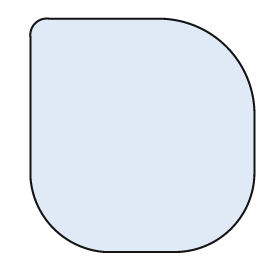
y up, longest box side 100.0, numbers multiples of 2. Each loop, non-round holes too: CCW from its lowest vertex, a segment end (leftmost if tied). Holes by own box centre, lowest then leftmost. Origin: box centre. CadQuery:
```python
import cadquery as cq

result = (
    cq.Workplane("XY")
    .moveTo(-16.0, -50.0)
    .lineTo(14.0, -50.0)
    .threePointArc((38.0, -40.0), (48.0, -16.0))
    .lineTo(48.0, 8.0)
    .threePointArc((36.0, 38.0), (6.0, 50.0))
    .lineTo(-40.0, 50.0)
    .threePointArc((-46.0, 48.0), (-48.0, 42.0))
    .lineTo(-48.0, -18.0)
    .threePointArc((-38.0, -40.0), (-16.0, -50.0))
    .close()
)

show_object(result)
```